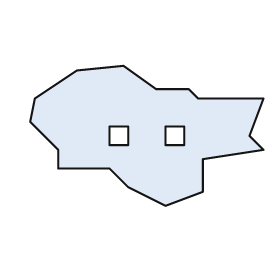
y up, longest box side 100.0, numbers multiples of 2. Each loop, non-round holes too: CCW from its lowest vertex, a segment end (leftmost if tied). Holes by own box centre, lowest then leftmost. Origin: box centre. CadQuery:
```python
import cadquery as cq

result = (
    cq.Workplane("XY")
    .moveTo(8.0, -30.0)
    .lineTo(24.0, -24.0)
    .lineTo(24.0, -10.0)
    .lineTo(50.0, -6.0)
    .lineTo(44.0, 0.0)
    .lineTo(50.0, 16.0)
    .lineTo(22.0, 16.0)
    .lineTo(18.0, 20.0)
    .lineTo(4.0, 20.0)
    .lineTo(-10.0, 30.0)
    .lineTo(-30.0, 28.0)
    .lineTo(-48.0, 16.0)
    .lineTo(-50.0, 6.0)
    .lineTo(-38.0, -6.0)
    .lineTo(-38.0, -14.0)
    .lineTo(-16.0, -14.0)
    .lineTo(-8.0, -22.0)
    .close()
    .moveTo(-16.0, -4.0)
    .lineTo(-8.0, -4.0)
    .lineTo(-8.0, 4.0)
    .lineTo(-16.0, 4.0)
    .close()
    .moveTo(8.0, -4.0)
    .lineTo(16.0, -4.0)
    .lineTo(16.0, 4.0)
    .lineTo(8.0, 4.0)
    .close()
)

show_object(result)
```